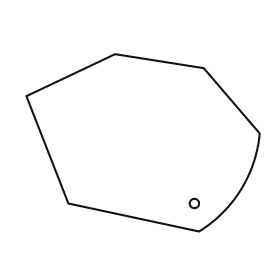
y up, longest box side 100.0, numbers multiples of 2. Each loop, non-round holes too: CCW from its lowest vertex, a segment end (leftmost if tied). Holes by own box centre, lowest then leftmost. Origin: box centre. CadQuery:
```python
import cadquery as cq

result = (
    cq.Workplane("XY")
    .moveTo(24.0, -38.0)
    .threePointArc((42.0, -20.0), (50.0, 4.0))
    .lineTo(26.0, 32.0)
    .lineTo(-12.0, 38.0)
    .lineTo(-50.0, 20.0)
    .lineTo(-32.0, -26.0)
    .close()
    .moveTo(22.0, -26.0)
    .circle(2.0)
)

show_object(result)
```